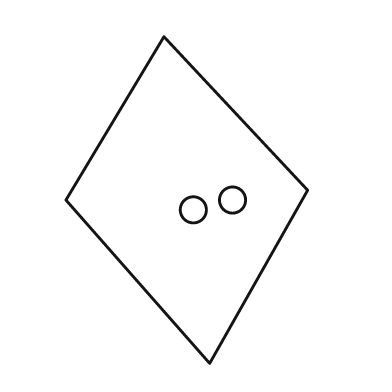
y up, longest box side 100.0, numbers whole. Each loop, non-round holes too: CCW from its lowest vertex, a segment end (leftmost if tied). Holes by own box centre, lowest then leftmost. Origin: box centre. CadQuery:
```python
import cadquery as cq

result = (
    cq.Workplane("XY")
    .moveTo(7.0, -50.0)
    .lineTo(37.0, 3.0)
    .lineTo(-7.0, 50.0)
    .lineTo(-37.0, 0.0)
    .close()
    .moveTo(2.0, -3.0)
    .circle(4.0)
    .moveTo(14.0, 0.0)
    .circle(4.0)
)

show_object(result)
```